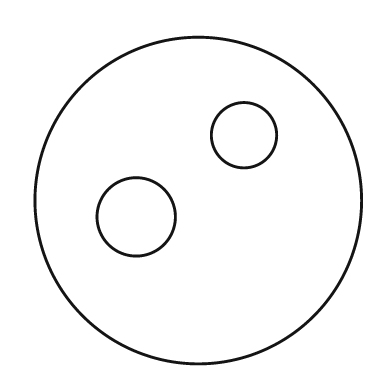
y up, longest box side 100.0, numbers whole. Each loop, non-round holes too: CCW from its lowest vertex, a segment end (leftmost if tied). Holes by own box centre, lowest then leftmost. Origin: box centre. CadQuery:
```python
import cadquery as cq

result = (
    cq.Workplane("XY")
    .moveTo(0.0, 0.0)
    .circle(50.0)
    .moveTo(-19.0, -5.0)
    .circle(12.0)
    .moveTo(14.0, 20.0)
    .circle(10.0)
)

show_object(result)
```